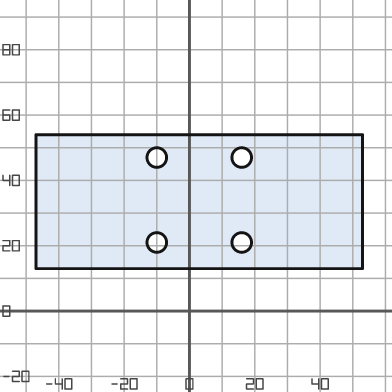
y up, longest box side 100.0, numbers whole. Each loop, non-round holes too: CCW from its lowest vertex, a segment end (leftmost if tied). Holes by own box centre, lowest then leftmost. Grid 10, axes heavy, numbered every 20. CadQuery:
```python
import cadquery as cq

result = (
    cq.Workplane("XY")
    .moveTo(-47.0, 13.0)
    .lineTo(53.0, 13.0)
    .lineTo(53.0, 54.0)
    .lineTo(-47.0, 54.0)
    .close()
    .moveTo(-10.0, 21.0)
    .circle(3.0)
    .moveTo(16.0, 21.0)
    .circle(3.0)
    .moveTo(-10.0, 47.0)
    .circle(3.0)
    .moveTo(16.0, 47.0)
    .circle(3.0)
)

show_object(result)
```